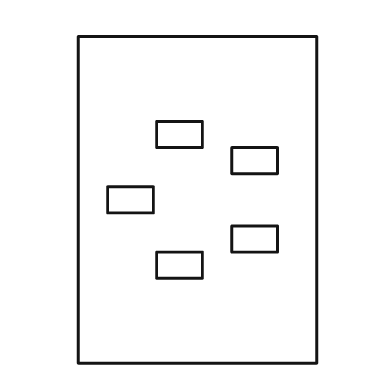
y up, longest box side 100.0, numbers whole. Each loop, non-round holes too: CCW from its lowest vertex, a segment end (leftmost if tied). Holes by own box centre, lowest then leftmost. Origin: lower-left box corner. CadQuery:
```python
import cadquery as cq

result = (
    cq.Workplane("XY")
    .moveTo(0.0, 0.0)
    .lineTo(73.0, 0.0)
    .lineTo(73.0, 100.0)
    .lineTo(0.0, 100.0)
    .close()
    .moveTo(24.0, 26.0)
    .lineTo(38.0, 26.0)
    .lineTo(38.0, 34.0)
    .lineTo(24.0, 34.0)
    .close()
    .moveTo(47.0, 34.0)
    .lineTo(61.0, 34.0)
    .lineTo(61.0, 42.0)
    .lineTo(47.0, 42.0)
    .close()
    .moveTo(9.0, 46.0)
    .lineTo(23.0, 46.0)
    .lineTo(23.0, 54.0)
    .lineTo(9.0, 54.0)
    .close()
    .moveTo(47.0, 58.0)
    .lineTo(61.0, 58.0)
    .lineTo(61.0, 66.0)
    .lineTo(47.0, 66.0)
    .close()
    .moveTo(24.0, 66.0)
    .lineTo(38.0, 66.0)
    .lineTo(38.0, 74.0)
    .lineTo(24.0, 74.0)
    .close()
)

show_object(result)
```